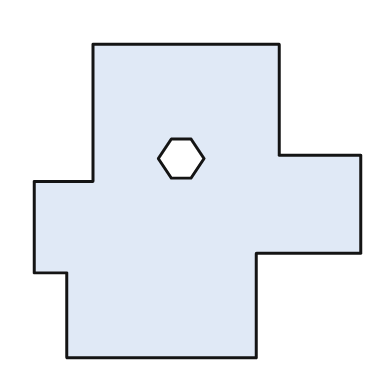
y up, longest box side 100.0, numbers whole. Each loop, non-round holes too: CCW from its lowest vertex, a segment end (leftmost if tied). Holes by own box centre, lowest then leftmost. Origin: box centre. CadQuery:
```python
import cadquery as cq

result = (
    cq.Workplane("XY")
    .moveTo(-40.0, -48.0)
    .lineTo(18.0, -48.0)
    .lineTo(18.0, -16.0)
    .lineTo(50.0, -16.0)
    .lineTo(50.0, 14.0)
    .lineTo(25.0, 14.0)
    .lineTo(25.0, 48.0)
    .lineTo(-32.0, 48.0)
    .lineTo(-32.0, 6.0)
    .lineTo(-50.0, 6.0)
    .lineTo(-50.0, -22.0)
    .lineTo(-40.0, -22.0)
    .close()
    .moveTo(-8.0, 7.0)
    .lineTo(-2.0, 7.0)
    .lineTo(2.0, 13.0)
    .lineTo(-2.0, 19.0)
    .lineTo(-8.0, 19.0)
    .lineTo(-12.0, 13.0)
    .close()
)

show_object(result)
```